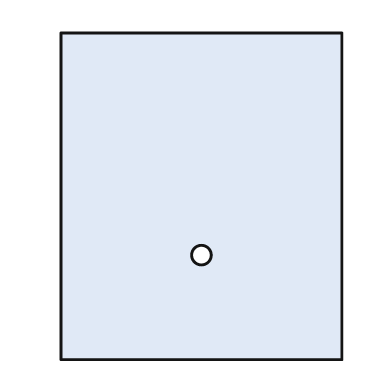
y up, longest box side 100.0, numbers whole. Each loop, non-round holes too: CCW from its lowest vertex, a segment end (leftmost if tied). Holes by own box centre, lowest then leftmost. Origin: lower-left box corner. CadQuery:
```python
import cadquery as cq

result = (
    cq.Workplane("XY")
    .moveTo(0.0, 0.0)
    .lineTo(86.0, 0.0)
    .lineTo(86.0, 100.0)
    .lineTo(0.0, 100.0)
    .close()
    .moveTo(43.0, 32.0)
    .circle(3.0)
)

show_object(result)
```